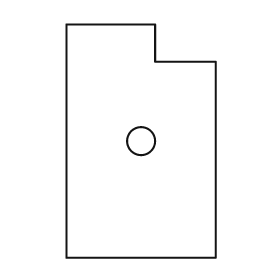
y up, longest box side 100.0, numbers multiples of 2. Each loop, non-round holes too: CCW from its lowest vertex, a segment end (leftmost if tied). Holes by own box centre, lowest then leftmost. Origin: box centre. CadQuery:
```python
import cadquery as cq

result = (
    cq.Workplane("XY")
    .moveTo(-32.0, -50.0)
    .lineTo(32.0, -50.0)
    .lineTo(32.0, 34.0)
    .lineTo(6.0, 34.0)
    .lineTo(6.0, 50.0)
    .lineTo(-32.0, 50.0)
    .close()
    .moveTo(0.0, 0.0)
    .circle(6.0)
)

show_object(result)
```